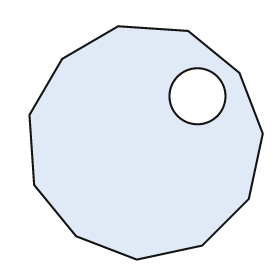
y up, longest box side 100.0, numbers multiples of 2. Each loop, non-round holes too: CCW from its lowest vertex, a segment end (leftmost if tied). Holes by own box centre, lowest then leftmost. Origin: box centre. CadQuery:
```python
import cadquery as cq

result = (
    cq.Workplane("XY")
    .moveTo(-4.0, -50.0)
    .lineTo(24.0, -44.0)
    .lineTo(44.0, -24.0)
    .lineTo(50.0, 4.0)
    .lineTo(40.0, 30.0)
    .lineTo(18.0, 48.0)
    .lineTo(-12.0, 50.0)
    .lineTo(-36.0, 36.0)
    .lineTo(-50.0, 12.0)
    .lineTo(-48.0, -18.0)
    .lineTo(-30.0, -40.0)
    .close()
    .moveTo(22.0, 20.0)
    .circle(12.0)
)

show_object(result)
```